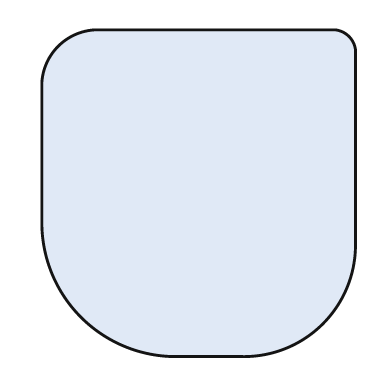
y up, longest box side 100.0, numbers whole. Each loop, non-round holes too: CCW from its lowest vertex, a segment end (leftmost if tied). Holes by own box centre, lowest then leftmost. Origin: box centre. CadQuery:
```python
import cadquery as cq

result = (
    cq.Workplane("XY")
    .moveTo(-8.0, -50.0)
    .lineTo(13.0, -50.0)
    .threePointArc((38.0, -40.0), (48.0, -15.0))
    .lineTo(48.0, 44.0)
    .threePointArc((46.0, 48.0), (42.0, 50.0))
    .lineTo(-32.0, 50.0)
    .threePointArc((-43.0, 45.0), (-48.0, 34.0))
    .lineTo(-48.0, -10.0)
    .threePointArc((-36.0, -38.0), (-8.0, -50.0))
    .close()
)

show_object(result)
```